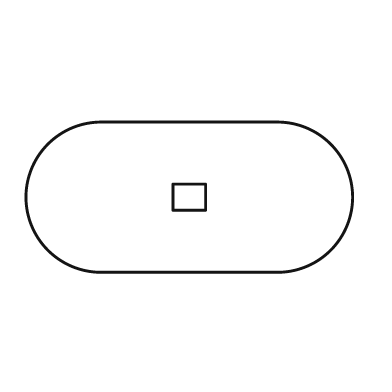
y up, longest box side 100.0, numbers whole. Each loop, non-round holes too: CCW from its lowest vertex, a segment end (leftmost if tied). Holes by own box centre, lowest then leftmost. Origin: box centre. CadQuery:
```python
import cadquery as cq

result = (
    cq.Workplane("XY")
    .moveTo(-27.0, -23.0)
    .lineTo(27.0, -23.0)
    .threePointArc((50.0, 0.0), (27.0, 23.0))
    .lineTo(-27.0, 23.0)
    .threePointArc((-50.0, 0.0), (-27.0, -23.0))
    .close()
    .moveTo(-5.0, -4.0)
    .lineTo(5.0, -4.0)
    .lineTo(5.0, 4.0)
    .lineTo(-5.0, 4.0)
    .close()
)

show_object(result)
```